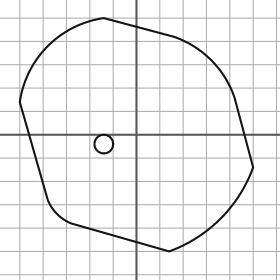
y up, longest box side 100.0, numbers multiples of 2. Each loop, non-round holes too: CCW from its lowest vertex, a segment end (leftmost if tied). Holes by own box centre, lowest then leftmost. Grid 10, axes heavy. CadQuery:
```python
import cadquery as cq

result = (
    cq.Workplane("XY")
    .moveTo(14.0, -50.0)
    .threePointArc((36.0, -36.0), (50.0, -14.0))
    .lineTo(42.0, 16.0)
    .threePointArc((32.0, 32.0), (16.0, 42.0))
    .lineTo(-14.0, 50.0)
    .threePointArc((-38.0, 38.0), (-50.0, 14.0))
    .lineTo(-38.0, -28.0)
    .threePointArc((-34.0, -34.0), (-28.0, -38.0))
    .close()
    .moveTo(-14.0, -4.0)
    .circle(4.0)
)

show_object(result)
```